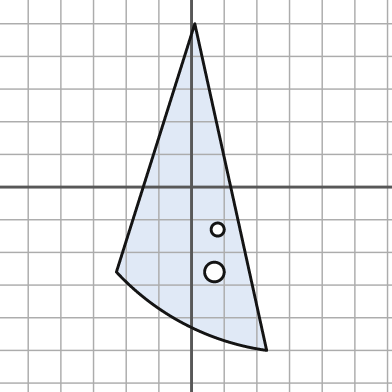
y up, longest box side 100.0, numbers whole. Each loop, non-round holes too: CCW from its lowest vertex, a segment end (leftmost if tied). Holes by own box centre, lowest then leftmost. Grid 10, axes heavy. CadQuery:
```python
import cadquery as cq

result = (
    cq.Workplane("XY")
    .moveTo(23.0, -50.0)
    .lineTo(1.0, 50.0)
    .lineTo(-23.0, -26.0)
    .threePointArc((-2.0, -42.0), (23.0, -50.0))
    .close()
    .moveTo(7.0, -26.0)
    .circle(3.0)
    .moveTo(8.0, -13.0)
    .circle(2.0)
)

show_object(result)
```